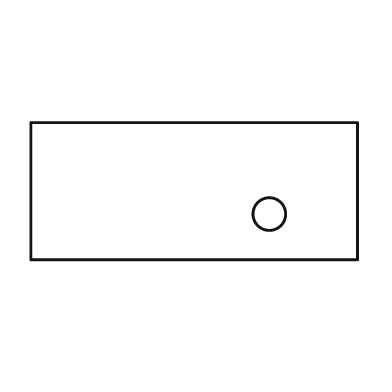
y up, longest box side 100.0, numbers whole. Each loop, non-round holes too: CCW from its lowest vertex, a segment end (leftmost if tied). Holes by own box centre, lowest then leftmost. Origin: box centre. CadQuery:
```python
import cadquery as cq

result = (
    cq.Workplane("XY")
    .moveTo(-50.0, -21.0)
    .lineTo(50.0, -21.0)
    .lineTo(50.0, 21.0)
    .lineTo(-50.0, 21.0)
    .close()
    .moveTo(23.0, -7.0)
    .circle(5.0)
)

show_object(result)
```